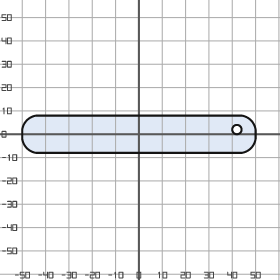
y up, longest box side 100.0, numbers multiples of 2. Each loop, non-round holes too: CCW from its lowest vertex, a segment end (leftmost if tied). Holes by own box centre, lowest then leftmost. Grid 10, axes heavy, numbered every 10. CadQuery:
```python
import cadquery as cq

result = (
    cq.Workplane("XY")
    .moveTo(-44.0, -8.0)
    .lineTo(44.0, -8.0)
    .threePointArc((48.0, -6.0), (50.0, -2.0))
    .lineTo(50.0, 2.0)
    .threePointArc((48.0, 6.0), (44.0, 8.0))
    .lineTo(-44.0, 8.0)
    .threePointArc((-48.0, 6.0), (-50.0, 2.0))
    .lineTo(-50.0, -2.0)
    .threePointArc((-48.0, -6.0), (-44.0, -8.0))
    .close()
    .moveTo(42.0, 2.0)
    .circle(2.0)
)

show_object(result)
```